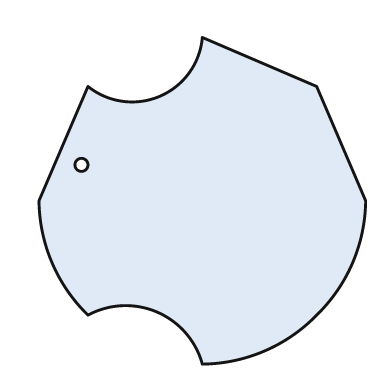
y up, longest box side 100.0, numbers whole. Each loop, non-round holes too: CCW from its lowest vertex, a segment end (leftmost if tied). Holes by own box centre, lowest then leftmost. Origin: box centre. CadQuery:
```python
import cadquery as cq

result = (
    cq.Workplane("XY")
    .moveTo(0.0, -50.0)
    .threePointArc((19.0, -46.0), (35.0, -35.0))
    .threePointArc((46.0, -19.0), (50.0, 0.0))
    .lineTo(35.0, 35.0)
    .lineTo(0.0, 50.0)
    .threePointArc((-13.0, 32.0), (-35.0, 35.0))
    .lineTo(-50.0, 0.0)
    .threePointArc((-46.0, -19.0), (-35.0, -35.0))
    .threePointArc((-14.0, -34.0), (0.0, -50.0))
    .close()
    .moveTo(-37.0, 11.0)
    .circle(2.0)
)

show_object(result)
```